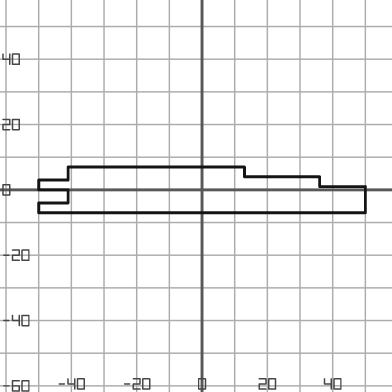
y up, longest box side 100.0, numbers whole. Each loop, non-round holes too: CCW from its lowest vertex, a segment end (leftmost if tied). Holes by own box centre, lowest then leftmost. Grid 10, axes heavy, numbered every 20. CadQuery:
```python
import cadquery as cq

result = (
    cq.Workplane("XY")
    .moveTo(-50.0, -7.0)
    .lineTo(50.0, -7.0)
    .lineTo(50.0, 1.0)
    .lineTo(36.0, 1.0)
    .lineTo(36.0, 4.0)
    .lineTo(13.0, 4.0)
    .lineTo(13.0, 7.0)
    .lineTo(-41.0, 7.0)
    .lineTo(-41.0, 3.0)
    .lineTo(-50.0, 3.0)
    .lineTo(-50.0, 0.0)
    .lineTo(-41.0, 0.0)
    .lineTo(-41.0, -4.0)
    .lineTo(-50.0, -4.0)
    .close()
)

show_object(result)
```